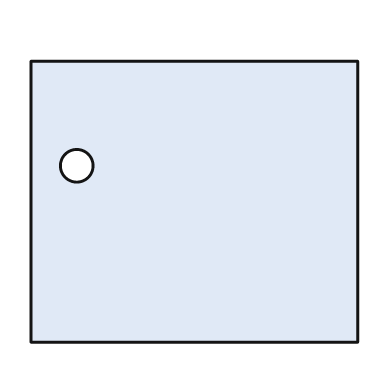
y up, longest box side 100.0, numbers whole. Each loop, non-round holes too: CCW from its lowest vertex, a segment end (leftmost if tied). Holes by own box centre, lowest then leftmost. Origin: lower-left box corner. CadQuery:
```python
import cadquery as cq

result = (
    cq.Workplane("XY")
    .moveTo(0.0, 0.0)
    .lineTo(100.0, 0.0)
    .lineTo(100.0, 86.0)
    .lineTo(0.0, 86.0)
    .close()
    .moveTo(14.0, 54.0)
    .circle(5.0)
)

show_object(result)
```